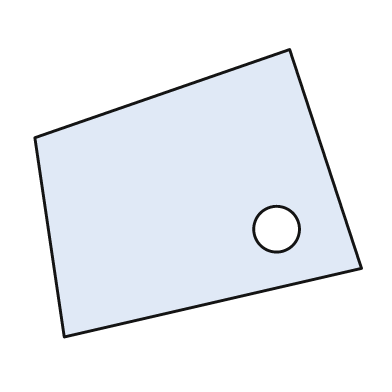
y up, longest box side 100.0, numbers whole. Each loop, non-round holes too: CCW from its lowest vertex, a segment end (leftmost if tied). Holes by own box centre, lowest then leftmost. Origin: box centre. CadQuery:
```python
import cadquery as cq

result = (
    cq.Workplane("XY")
    .moveTo(-41.0, -44.0)
    .lineTo(50.0, -23.0)
    .lineTo(28.0, 44.0)
    .lineTo(-50.0, 17.0)
    .close()
    .moveTo(24.0, -11.0)
    .circle(7.0)
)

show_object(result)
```